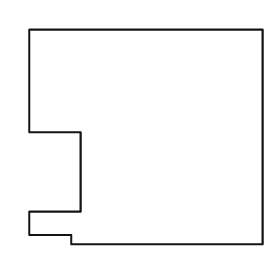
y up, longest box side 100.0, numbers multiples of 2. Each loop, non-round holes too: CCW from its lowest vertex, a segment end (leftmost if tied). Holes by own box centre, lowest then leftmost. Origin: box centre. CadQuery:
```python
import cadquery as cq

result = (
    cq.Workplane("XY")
    .moveTo(-32.0, -46.0)
    .lineTo(50.0, -46.0)
    .lineTo(50.0, 46.0)
    .lineTo(-50.0, 46.0)
    .lineTo(-50.0, 2.0)
    .lineTo(-28.0, 2.0)
    .lineTo(-28.0, -32.0)
    .lineTo(-50.0, -32.0)
    .lineTo(-50.0, -42.0)
    .lineTo(-32.0, -42.0)
    .close()
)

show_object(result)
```